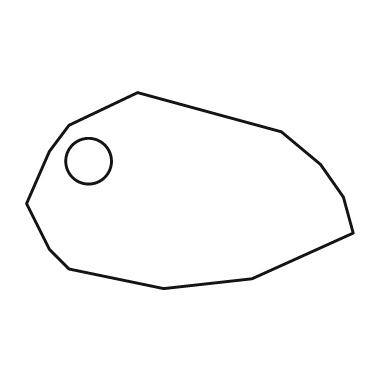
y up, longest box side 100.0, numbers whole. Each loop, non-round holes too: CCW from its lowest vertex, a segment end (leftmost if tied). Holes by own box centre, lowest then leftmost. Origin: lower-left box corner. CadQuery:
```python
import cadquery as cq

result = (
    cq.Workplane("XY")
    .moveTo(42.0, 0.0)
    .lineTo(69.0, 3.0)
    .lineTo(100.0, 17.0)
    .lineTo(97.0, 28.0)
    .lineTo(90.0, 38.0)
    .lineTo(78.0, 48.0)
    .lineTo(34.0, 60.0)
    .lineTo(13.0, 50.0)
    .lineTo(7.0, 42.0)
    .lineTo(0.0, 26.0)
    .lineTo(7.0, 12.0)
    .lineTo(13.0, 6.0)
    .close()
    .moveTo(19.0, 39.0)
    .circle(7.0)
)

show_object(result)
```